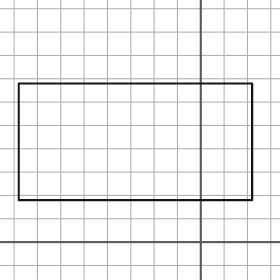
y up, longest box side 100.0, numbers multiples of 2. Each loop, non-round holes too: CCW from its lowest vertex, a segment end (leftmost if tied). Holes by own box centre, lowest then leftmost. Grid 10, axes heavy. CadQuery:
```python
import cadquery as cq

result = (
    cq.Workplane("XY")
    .moveTo(-78.0, 18.0)
    .lineTo(22.0, 18.0)
    .lineTo(22.0, 68.0)
    .lineTo(-78.0, 68.0)
    .close()
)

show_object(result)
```